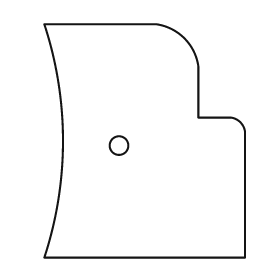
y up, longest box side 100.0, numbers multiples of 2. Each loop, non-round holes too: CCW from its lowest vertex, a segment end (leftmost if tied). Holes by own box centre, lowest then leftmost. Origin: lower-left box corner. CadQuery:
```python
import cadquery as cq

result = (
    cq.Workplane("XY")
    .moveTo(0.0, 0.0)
    .lineTo(86.0, 0.0)
    .lineTo(86.0, 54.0)
    .threePointArc((84.0, 58.0), (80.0, 60.0))
    .lineTo(66.0, 60.0)
    .lineTo(66.0, 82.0)
    .threePointArc((60.0, 94.0), (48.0, 100.0))
    .lineTo(0.0, 100.0)
    .threePointArc((8.0, 50.0), (0.0, 0.0))
    .close()
    .moveTo(32.0, 48.0)
    .circle(4.0)
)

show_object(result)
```